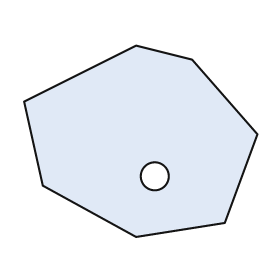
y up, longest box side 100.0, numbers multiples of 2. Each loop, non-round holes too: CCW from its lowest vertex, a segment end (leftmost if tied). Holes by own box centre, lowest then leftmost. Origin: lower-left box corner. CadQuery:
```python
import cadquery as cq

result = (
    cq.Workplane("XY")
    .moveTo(48.0, 0.0)
    .lineTo(86.0, 6.0)
    .lineTo(100.0, 44.0)
    .lineTo(72.0, 76.0)
    .lineTo(48.0, 82.0)
    .lineTo(0.0, 58.0)
    .lineTo(8.0, 22.0)
    .close()
    .moveTo(56.0, 26.0)
    .circle(6.0)
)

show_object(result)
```